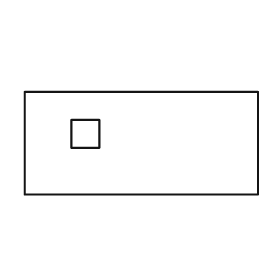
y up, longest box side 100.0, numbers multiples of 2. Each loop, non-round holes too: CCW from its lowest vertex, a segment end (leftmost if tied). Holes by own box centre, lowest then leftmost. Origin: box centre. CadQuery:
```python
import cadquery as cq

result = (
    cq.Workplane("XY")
    .moveTo(-50.0, -22.0)
    .lineTo(50.0, -22.0)
    .lineTo(50.0, 22.0)
    .lineTo(-50.0, 22.0)
    .close()
    .moveTo(-30.0, -2.0)
    .lineTo(-18.0, -2.0)
    .lineTo(-18.0, 10.0)
    .lineTo(-30.0, 10.0)
    .close()
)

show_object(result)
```